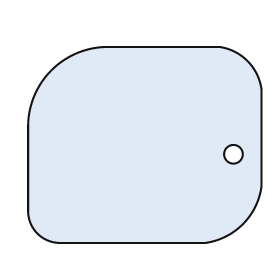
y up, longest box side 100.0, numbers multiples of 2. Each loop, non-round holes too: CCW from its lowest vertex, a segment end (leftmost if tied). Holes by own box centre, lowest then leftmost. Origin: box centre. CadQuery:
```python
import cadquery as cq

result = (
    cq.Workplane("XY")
    .moveTo(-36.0, -42.0)
    .lineTo(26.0, -42.0)
    .threePointArc((42.0, -34.0), (50.0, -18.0))
    .lineTo(50.0, 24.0)
    .threePointArc((44.0, 36.0), (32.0, 42.0))
    .lineTo(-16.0, 42.0)
    .threePointArc((-40.0, 32.0), (-50.0, 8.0))
    .lineTo(-50.0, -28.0)
    .threePointArc((-46.0, -38.0), (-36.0, -42.0))
    .close()
    .moveTo(38.0, -4.0)
    .circle(4.0)
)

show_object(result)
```